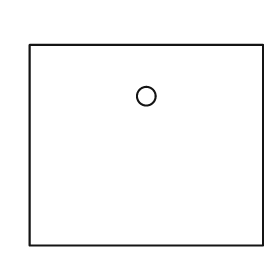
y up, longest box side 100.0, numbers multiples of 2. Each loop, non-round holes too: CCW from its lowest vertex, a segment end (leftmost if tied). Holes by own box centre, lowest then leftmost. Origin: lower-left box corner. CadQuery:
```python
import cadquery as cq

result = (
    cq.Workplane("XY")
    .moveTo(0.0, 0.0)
    .lineTo(100.0, 0.0)
    .lineTo(100.0, 86.0)
    .lineTo(0.0, 86.0)
    .close()
    .moveTo(50.0, 64.0)
    .circle(4.0)
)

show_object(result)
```